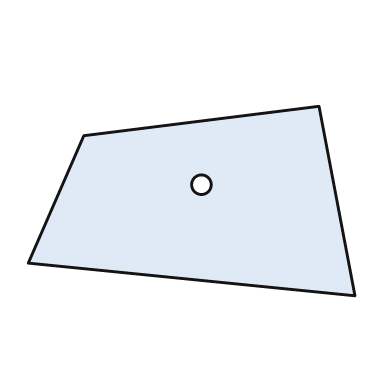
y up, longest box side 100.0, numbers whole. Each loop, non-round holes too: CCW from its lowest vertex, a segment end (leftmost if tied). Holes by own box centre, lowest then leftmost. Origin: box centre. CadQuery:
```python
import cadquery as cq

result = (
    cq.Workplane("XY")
    .moveTo(50.0, -29.0)
    .lineTo(39.0, 29.0)
    .lineTo(-33.0, 20.0)
    .lineTo(-50.0, -19.0)
    .close()
    .moveTo(3.0, 5.0)
    .circle(3.0)
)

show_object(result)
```